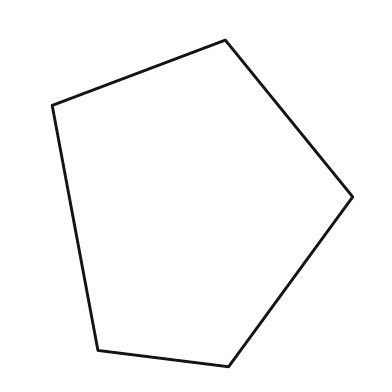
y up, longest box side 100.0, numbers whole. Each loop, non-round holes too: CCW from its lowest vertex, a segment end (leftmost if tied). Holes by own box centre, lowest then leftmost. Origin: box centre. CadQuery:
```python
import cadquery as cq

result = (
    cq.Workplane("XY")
    .moveTo(8.0, -50.0)
    .lineTo(46.0, 2.0)
    .lineTo(7.0, 50.0)
    .lineTo(-46.0, 30.0)
    .lineTo(-32.0, -45.0)
    .close()
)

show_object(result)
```